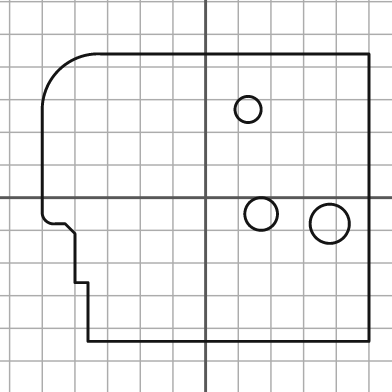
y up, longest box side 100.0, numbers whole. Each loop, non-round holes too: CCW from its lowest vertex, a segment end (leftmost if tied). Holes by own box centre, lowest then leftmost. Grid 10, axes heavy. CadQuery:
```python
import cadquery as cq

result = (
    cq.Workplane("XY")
    .moveTo(-36.0, -44.0)
    .lineTo(50.0, -44.0)
    .lineTo(50.0, 44.0)
    .lineTo(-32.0, 44.0)
    .threePointArc((-45.0, 39.0), (-50.0, 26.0))
    .lineTo(-50.0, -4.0)
    .threePointArc((-49.0, -7.0), (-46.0, -8.0))
    .lineTo(-43.0, -8.0)
    .lineTo(-40.0, -11.0)
    .lineTo(-40.0, -26.0)
    .lineTo(-36.0, -26.0)
    .close()
    .moveTo(38.0, -8.0)
    .circle(6.0)
    .moveTo(17.0, -5.0)
    .circle(5.0)
    .moveTo(13.0, 27.0)
    .circle(4.0)
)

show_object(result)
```